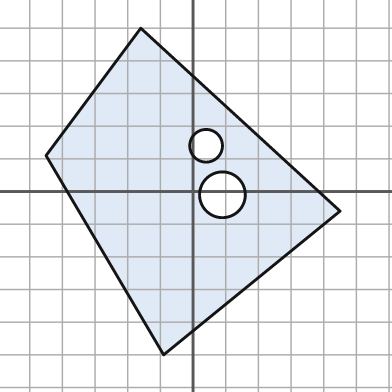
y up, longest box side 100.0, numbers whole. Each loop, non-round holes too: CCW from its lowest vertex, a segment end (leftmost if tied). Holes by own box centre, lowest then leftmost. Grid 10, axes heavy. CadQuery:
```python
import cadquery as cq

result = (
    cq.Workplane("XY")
    .moveTo(-9.0, -50.0)
    .lineTo(45.0, -6.0)
    .lineTo(-16.0, 50.0)
    .lineTo(-45.0, 11.0)
    .close()
    .moveTo(9.0, -1.0)
    .circle(7.0)
    .moveTo(4.0, 14.0)
    .circle(5.0)
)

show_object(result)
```